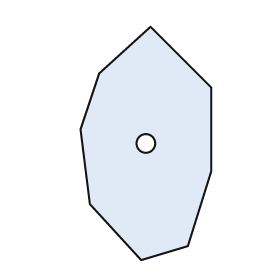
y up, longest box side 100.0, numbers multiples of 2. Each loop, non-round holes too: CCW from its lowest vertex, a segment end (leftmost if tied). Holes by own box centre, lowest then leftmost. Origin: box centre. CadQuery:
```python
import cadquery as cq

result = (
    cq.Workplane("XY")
    .moveTo(-2.0, -50.0)
    .lineTo(18.0, -44.0)
    .lineTo(28.0, -12.0)
    .lineTo(28.0, 24.0)
    .lineTo(2.0, 50.0)
    .lineTo(-20.0, 30.0)
    .lineTo(-28.0, 6.0)
    .lineTo(-24.0, -26.0)
    .close()
    .moveTo(0.0, 0.0)
    .circle(4.0)
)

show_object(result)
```